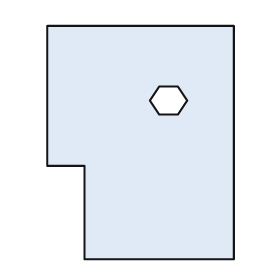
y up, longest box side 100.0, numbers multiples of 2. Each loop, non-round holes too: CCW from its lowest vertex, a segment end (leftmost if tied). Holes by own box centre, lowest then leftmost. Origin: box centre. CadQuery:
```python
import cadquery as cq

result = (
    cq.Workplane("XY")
    .moveTo(-24.0, -50.0)
    .lineTo(40.0, -50.0)
    .lineTo(40.0, 50.0)
    .lineTo(-40.0, 50.0)
    .lineTo(-40.0, -10.0)
    .lineTo(-24.0, -10.0)
    .close()
    .moveTo(8.0, 12.0)
    .lineTo(16.0, 12.0)
    .lineTo(20.0, 18.0)
    .lineTo(16.0, 24.0)
    .lineTo(8.0, 24.0)
    .lineTo(4.0, 18.0)
    .close()
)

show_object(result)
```